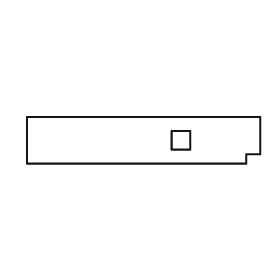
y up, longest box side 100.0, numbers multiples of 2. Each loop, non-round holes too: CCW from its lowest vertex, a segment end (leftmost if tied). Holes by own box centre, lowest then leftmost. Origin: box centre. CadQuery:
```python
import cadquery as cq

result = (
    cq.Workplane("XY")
    .moveTo(-50.0, -10.0)
    .lineTo(44.0, -10.0)
    .lineTo(44.0, -6.0)
    .lineTo(50.0, -6.0)
    .lineTo(50.0, 10.0)
    .lineTo(-50.0, 10.0)
    .close()
    .moveTo(12.0, -4.0)
    .lineTo(20.0, -4.0)
    .lineTo(20.0, 4.0)
    .lineTo(12.0, 4.0)
    .close()
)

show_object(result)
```